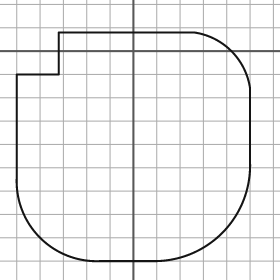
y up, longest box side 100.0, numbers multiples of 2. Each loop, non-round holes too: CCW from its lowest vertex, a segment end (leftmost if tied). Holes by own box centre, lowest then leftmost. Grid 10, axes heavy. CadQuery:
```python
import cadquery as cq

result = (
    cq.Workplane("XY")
    .moveTo(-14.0, -90.0)
    .lineTo(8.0, -90.0)
    .threePointArc((38.0, -78.0), (50.0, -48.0))
    .lineTo(50.0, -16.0)
    .threePointArc((42.0, 0.0), (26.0, 8.0))
    .lineTo(-32.0, 8.0)
    .lineTo(-32.0, -10.0)
    .lineTo(-50.0, -10.0)
    .lineTo(-50.0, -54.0)
    .threePointArc((-40.0, -80.0), (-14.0, -90.0))
    .close()
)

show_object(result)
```